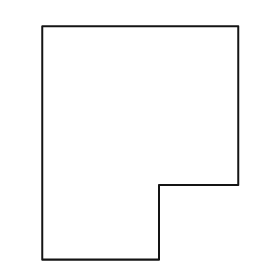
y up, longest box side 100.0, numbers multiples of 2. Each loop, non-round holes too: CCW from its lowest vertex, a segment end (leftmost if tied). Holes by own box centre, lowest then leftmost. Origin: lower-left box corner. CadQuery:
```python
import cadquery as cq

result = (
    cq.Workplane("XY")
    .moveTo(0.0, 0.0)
    .lineTo(50.0, 0.0)
    .lineTo(50.0, 32.0)
    .lineTo(84.0, 32.0)
    .lineTo(84.0, 100.0)
    .lineTo(0.0, 100.0)
    .close()
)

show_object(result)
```